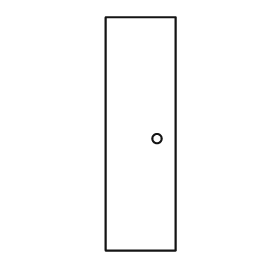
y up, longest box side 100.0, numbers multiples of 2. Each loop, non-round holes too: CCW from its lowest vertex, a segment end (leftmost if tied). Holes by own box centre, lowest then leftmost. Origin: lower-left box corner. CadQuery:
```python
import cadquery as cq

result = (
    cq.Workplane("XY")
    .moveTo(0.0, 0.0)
    .lineTo(30.0, 0.0)
    .lineTo(30.0, 100.0)
    .lineTo(0.0, 100.0)
    .close()
    .moveTo(22.0, 48.0)
    .circle(2.0)
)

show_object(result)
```